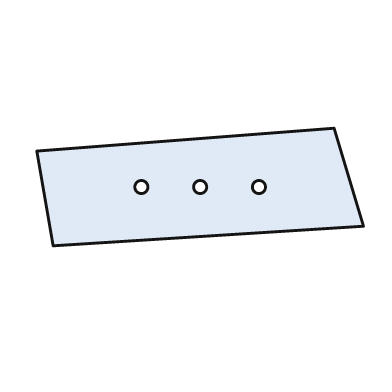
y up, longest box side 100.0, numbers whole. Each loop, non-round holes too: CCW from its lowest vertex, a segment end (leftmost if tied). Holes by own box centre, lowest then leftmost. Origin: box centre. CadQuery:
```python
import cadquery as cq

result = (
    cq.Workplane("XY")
    .moveTo(-45.0, -18.0)
    .lineTo(50.0, -12.0)
    .lineTo(41.0, 18.0)
    .lineTo(-50.0, 11.0)
    .close()
    .moveTo(-18.0, 0.0)
    .circle(2.0)
    .moveTo(0.0, 0.0)
    .circle(2.0)
    .moveTo(18.0, 0.0)
    .circle(2.0)
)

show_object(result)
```